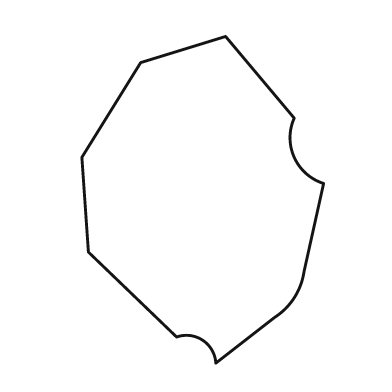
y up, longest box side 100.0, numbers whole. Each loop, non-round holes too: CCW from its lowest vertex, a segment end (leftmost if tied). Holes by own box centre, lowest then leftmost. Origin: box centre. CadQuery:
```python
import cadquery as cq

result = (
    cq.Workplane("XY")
    .moveTo(4.0, -50.0)
    .lineTo(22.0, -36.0)
    .threePointArc((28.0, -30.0), (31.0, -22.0))
    .lineTo(37.0, 5.0)
    .threePointArc((28.0, 13.0), (28.0, 25.0))
    .lineTo(7.0, 50.0)
    .lineTo(-19.0, 42.0)
    .lineTo(-37.0, 13.0)
    .lineTo(-35.0, -16.0)
    .lineTo(-8.0, -42.0)
    .threePointArc((0.0, -43.0), (4.0, -50.0))
    .close()
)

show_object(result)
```